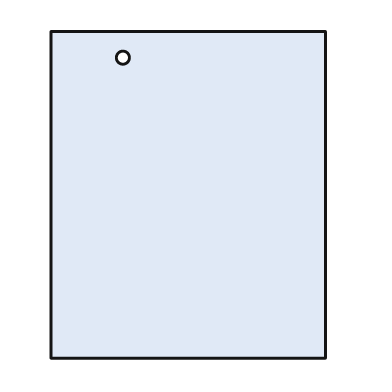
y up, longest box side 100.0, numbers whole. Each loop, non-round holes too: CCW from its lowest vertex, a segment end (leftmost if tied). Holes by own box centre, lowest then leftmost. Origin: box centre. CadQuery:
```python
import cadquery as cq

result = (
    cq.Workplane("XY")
    .moveTo(-42.0, -50.0)
    .lineTo(42.0, -50.0)
    .lineTo(42.0, 50.0)
    .lineTo(-42.0, 50.0)
    .close()
    .moveTo(-20.0, 42.0)
    .circle(2.0)
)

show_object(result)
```